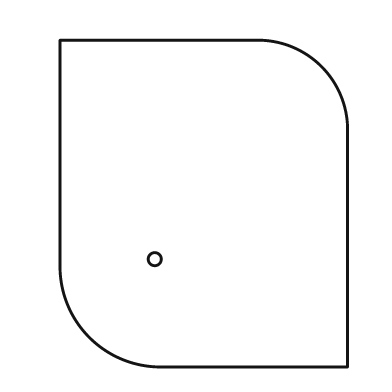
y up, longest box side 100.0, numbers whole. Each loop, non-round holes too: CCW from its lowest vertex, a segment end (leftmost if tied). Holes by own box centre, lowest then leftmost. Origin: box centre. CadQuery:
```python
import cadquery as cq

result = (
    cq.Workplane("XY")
    .moveTo(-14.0, -50.0)
    .lineTo(44.0, -50.0)
    .lineTo(44.0, 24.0)
    .threePointArc((36.0, 42.0), (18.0, 50.0))
    .lineTo(-44.0, 50.0)
    .lineTo(-44.0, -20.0)
    .threePointArc((-35.0, -41.0), (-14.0, -50.0))
    .close()
    .moveTo(-15.0, -17.0)
    .circle(2.0)
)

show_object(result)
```